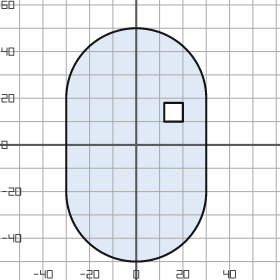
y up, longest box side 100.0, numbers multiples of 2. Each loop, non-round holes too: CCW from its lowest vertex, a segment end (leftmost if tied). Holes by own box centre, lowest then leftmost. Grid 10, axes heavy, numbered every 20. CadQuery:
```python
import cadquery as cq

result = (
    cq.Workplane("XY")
    .moveTo(-30.0, -20.0)
    .threePointArc((0.0, -50.0), (30.0, -20.0))
    .lineTo(30.0, 20.0)
    .threePointArc((0.0, 50.0), (-30.0, 20.0))
    .close()
    .moveTo(12.0, 10.0)
    .lineTo(20.0, 10.0)
    .lineTo(20.0, 18.0)
    .lineTo(12.0, 18.0)
    .close()
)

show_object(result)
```